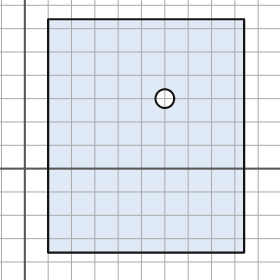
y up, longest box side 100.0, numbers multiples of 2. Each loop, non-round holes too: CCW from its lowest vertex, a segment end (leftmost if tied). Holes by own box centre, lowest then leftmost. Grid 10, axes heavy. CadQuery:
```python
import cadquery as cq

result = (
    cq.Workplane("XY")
    .moveTo(10.0, -36.0)
    .lineTo(94.0, -36.0)
    .lineTo(94.0, 64.0)
    .lineTo(10.0, 64.0)
    .close()
    .moveTo(60.0, 30.0)
    .circle(4.0)
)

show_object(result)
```